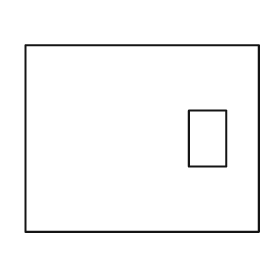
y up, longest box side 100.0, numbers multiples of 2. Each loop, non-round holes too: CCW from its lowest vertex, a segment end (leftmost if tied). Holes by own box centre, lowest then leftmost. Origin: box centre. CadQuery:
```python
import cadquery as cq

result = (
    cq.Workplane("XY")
    .moveTo(-50.0, -40.0)
    .lineTo(50.0, -40.0)
    .lineTo(50.0, 40.0)
    .lineTo(-50.0, 40.0)
    .close()
    .moveTo(20.0, -12.0)
    .lineTo(36.0, -12.0)
    .lineTo(36.0, 12.0)
    .lineTo(20.0, 12.0)
    .close()
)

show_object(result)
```